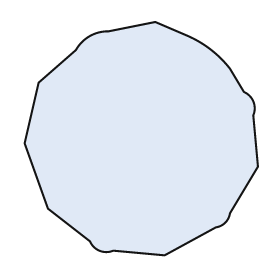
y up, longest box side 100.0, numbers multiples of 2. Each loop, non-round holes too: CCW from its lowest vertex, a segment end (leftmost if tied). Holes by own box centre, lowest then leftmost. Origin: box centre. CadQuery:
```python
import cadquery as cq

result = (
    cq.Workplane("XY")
    .moveTo(10.0, -50.0)
    .lineTo(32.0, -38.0)
    .threePointArc((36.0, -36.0), (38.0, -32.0))
    .lineTo(50.0, -12.0)
    .lineTo(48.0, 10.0)
    .threePointArc((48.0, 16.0), (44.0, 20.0))
    .lineTo(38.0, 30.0)
    .threePointArc((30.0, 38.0), (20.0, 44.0))
    .lineTo(6.0, 50.0)
    .lineTo(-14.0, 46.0)
    .threePointArc((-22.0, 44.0), (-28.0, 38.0))
    .lineTo(-44.0, 24.0)
    .lineTo(-50.0, -2.0)
    .lineTo(-40.0, -30.0)
    .lineTo(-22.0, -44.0)
    .threePointArc((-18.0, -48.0), (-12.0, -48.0))
    .close()
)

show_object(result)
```